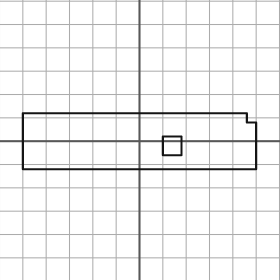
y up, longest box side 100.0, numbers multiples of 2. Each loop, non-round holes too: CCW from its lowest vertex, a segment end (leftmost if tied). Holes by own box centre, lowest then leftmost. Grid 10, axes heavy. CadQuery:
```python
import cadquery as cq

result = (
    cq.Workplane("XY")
    .moveTo(-50.0, -12.0)
    .lineTo(50.0, -12.0)
    .lineTo(50.0, 8.0)
    .lineTo(46.0, 8.0)
    .lineTo(46.0, 12.0)
    .lineTo(-50.0, 12.0)
    .close()
    .moveTo(10.0, -6.0)
    .lineTo(18.0, -6.0)
    .lineTo(18.0, 2.0)
    .lineTo(10.0, 2.0)
    .close()
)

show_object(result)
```